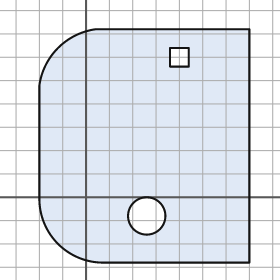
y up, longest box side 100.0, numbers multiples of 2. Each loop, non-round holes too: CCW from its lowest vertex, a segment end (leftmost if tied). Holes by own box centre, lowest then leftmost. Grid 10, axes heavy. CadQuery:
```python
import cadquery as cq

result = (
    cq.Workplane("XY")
    .moveTo(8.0, -28.0)
    .lineTo(70.0, -28.0)
    .lineTo(70.0, 72.0)
    .lineTo(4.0, 72.0)
    .threePointArc((-12.0, 64.0), (-20.0, 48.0))
    .lineTo(-20.0, 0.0)
    .threePointArc((-12.0, -20.0), (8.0, -28.0))
    .close()
    .moveTo(26.0, -8.0)
    .circle(8.0)
    .moveTo(36.0, 56.0)
    .lineTo(44.0, 56.0)
    .lineTo(44.0, 64.0)
    .lineTo(36.0, 64.0)
    .close()
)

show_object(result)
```